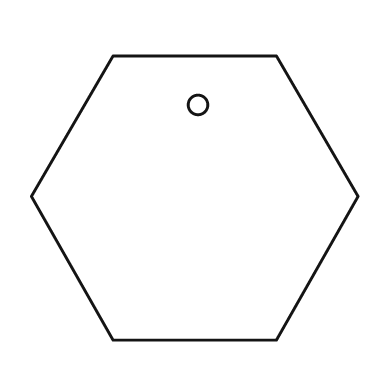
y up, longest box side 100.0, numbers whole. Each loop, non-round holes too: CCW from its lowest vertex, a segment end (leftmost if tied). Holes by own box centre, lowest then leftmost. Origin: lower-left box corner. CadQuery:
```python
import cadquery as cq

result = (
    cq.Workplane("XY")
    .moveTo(25.0, 0.0)
    .lineTo(75.0, 0.0)
    .lineTo(100.0, 44.0)
    .lineTo(75.0, 87.0)
    .lineTo(25.0, 87.0)
    .lineTo(0.0, 44.0)
    .close()
    .moveTo(51.0, 72.0)
    .circle(3.0)
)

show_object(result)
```